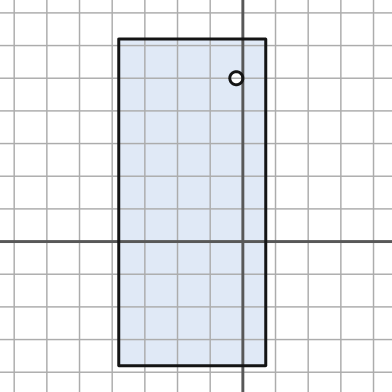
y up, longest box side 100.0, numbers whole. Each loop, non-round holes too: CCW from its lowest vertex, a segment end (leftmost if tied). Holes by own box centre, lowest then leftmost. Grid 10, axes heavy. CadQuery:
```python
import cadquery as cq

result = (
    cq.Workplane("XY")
    .moveTo(-38.0, -38.0)
    .lineTo(7.0, -38.0)
    .lineTo(7.0, 62.0)
    .lineTo(-38.0, 62.0)
    .close()
    .moveTo(-2.0, 50.0)
    .circle(2.0)
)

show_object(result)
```